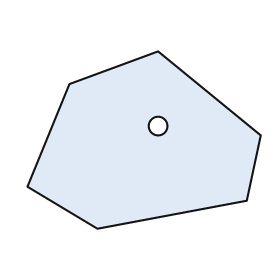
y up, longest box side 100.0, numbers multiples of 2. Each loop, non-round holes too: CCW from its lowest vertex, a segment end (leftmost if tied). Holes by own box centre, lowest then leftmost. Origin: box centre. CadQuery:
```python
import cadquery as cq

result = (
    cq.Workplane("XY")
    .moveTo(-20.0, -38.0)
    .lineTo(44.0, -26.0)
    .lineTo(50.0, 2.0)
    .lineTo(6.0, 38.0)
    .lineTo(-32.0, 24.0)
    .lineTo(-50.0, -20.0)
    .close()
    .moveTo(6.0, 6.0)
    .circle(4.0)
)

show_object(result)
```